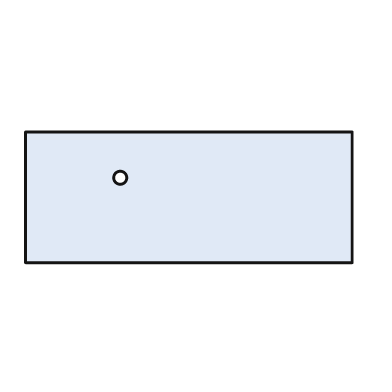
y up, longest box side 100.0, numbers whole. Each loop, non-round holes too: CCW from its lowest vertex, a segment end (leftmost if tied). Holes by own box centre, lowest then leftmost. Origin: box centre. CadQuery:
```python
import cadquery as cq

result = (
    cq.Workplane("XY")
    .moveTo(-50.0, -20.0)
    .lineTo(50.0, -20.0)
    .lineTo(50.0, 20.0)
    .lineTo(-50.0, 20.0)
    .close()
    .moveTo(-21.0, 6.0)
    .circle(2.0)
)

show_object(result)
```